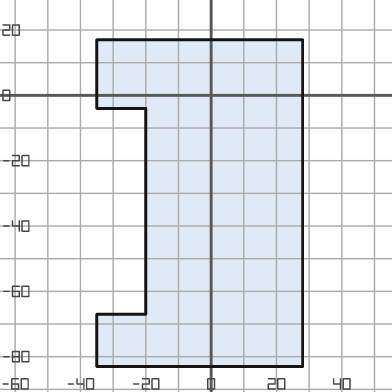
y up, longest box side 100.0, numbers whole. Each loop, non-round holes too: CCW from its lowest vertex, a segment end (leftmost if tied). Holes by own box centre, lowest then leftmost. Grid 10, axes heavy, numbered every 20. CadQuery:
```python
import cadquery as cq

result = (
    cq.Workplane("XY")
    .moveTo(-35.0, -83.0)
    .lineTo(28.0, -83.0)
    .lineTo(28.0, 17.0)
    .lineTo(-35.0, 17.0)
    .lineTo(-35.0, -4.0)
    .lineTo(-20.0, -4.0)
    .lineTo(-20.0, -67.0)
    .lineTo(-35.0, -67.0)
    .close()
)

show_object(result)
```